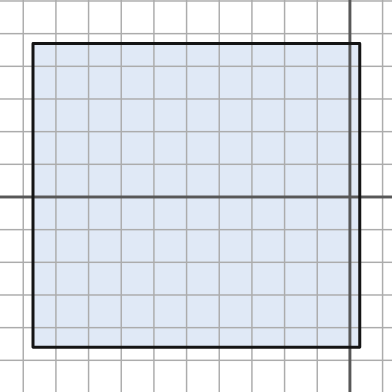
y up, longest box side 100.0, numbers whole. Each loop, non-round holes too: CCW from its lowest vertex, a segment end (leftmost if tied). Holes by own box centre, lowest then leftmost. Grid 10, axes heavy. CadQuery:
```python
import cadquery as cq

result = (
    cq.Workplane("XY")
    .moveTo(-97.0, -46.0)
    .lineTo(3.0, -46.0)
    .lineTo(3.0, 47.0)
    .lineTo(-97.0, 47.0)
    .close()
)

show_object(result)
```